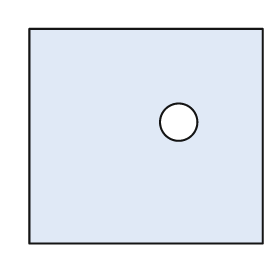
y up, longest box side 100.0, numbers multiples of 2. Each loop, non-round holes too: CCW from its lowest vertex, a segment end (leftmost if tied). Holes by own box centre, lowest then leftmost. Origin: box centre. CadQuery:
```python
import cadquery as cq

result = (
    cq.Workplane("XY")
    .moveTo(-50.0, -46.0)
    .lineTo(50.0, -46.0)
    .lineTo(50.0, 46.0)
    .lineTo(-50.0, 46.0)
    .close()
    .moveTo(14.0, 6.0)
    .circle(8.0)
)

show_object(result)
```